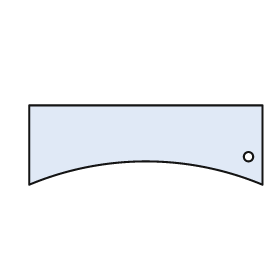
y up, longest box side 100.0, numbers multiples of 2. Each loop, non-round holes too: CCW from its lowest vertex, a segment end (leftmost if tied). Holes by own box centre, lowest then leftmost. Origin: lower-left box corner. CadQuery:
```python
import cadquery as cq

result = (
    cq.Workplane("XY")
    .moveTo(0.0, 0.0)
    .threePointArc((50.0, 10.0), (100.0, 0.0))
    .lineTo(100.0, 34.0)
    .lineTo(0.0, 34.0)
    .close()
    .moveTo(94.0, 12.0)
    .circle(2.0)
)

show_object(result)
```